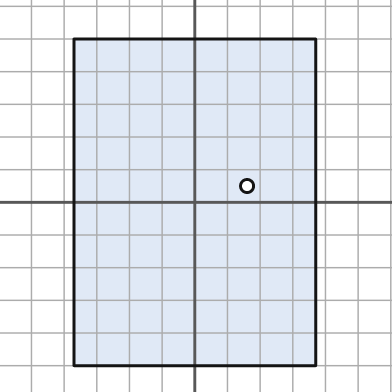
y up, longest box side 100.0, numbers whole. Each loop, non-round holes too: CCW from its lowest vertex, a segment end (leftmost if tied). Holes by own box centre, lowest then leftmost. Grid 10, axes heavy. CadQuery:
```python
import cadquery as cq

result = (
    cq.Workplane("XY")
    .moveTo(-37.0, -50.0)
    .lineTo(37.0, -50.0)
    .lineTo(37.0, 50.0)
    .lineTo(-37.0, 50.0)
    .close()
    .moveTo(16.0, 5.0)
    .circle(2.0)
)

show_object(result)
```